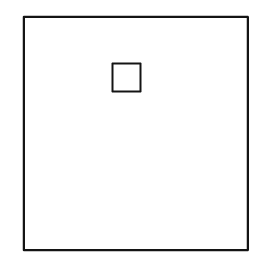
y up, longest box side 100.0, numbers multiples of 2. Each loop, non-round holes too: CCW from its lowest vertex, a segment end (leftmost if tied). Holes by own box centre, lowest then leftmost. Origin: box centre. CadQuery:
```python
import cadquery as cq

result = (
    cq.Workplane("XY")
    .moveTo(-48.0, -50.0)
    .lineTo(48.0, -50.0)
    .lineTo(48.0, 50.0)
    .lineTo(-48.0, 50.0)
    .close()
    .moveTo(-10.0, 18.0)
    .lineTo(2.0, 18.0)
    .lineTo(2.0, 30.0)
    .lineTo(-10.0, 30.0)
    .close()
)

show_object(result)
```